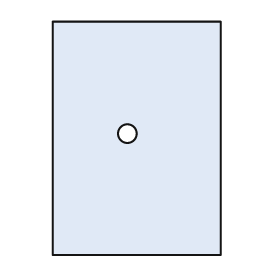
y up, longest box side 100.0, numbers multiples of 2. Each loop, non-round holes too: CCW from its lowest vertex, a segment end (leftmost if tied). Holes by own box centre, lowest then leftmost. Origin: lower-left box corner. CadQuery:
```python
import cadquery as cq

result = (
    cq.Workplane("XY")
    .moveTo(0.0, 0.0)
    .lineTo(72.0, 0.0)
    .lineTo(72.0, 100.0)
    .lineTo(0.0, 100.0)
    .close()
    .moveTo(32.0, 52.0)
    .circle(4.0)
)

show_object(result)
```